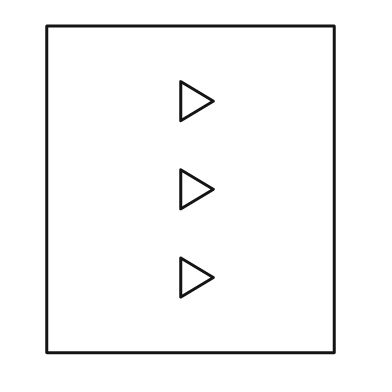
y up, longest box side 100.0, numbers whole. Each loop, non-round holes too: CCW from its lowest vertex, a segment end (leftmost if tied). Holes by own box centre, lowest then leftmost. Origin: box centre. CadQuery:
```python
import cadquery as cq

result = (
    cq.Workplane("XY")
    .moveTo(-44.0, -50.0)
    .lineTo(44.0, -50.0)
    .lineTo(44.0, 50.0)
    .lineTo(-44.0, 50.0)
    .close()
    .moveTo(-3.0, -33.0)
    .lineTo(7.0, -27.0)
    .lineTo(-3.0, -21.0)
    .close()
    .moveTo(-3.0, -6.0)
    .lineTo(7.0, 0.0)
    .lineTo(-3.0, 6.0)
    .close()
    .moveTo(-3.0, 21.0)
    .lineTo(7.0, 27.0)
    .lineTo(-3.0, 33.0)
    .close()
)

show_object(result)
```